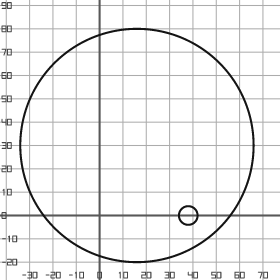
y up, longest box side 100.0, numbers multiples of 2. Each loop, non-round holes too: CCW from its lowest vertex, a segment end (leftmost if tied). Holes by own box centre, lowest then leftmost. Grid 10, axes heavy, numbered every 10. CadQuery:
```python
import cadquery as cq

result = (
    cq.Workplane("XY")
    .moveTo(16.0, 30.0)
    .circle(50.0)
    .moveTo(38.0, 0.0)
    .circle(4.0)
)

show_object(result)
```